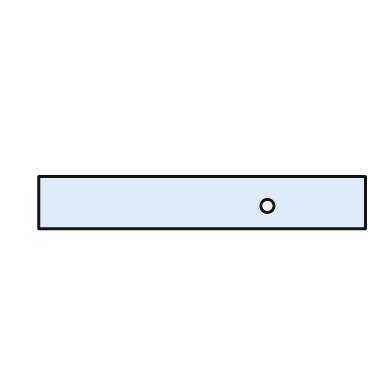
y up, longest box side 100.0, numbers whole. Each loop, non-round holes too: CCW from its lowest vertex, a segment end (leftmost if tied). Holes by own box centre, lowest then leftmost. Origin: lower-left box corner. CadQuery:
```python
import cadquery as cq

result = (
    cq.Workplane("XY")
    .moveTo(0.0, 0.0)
    .lineTo(100.0, 0.0)
    .lineTo(100.0, 16.0)
    .lineTo(0.0, 16.0)
    .close()
    .moveTo(70.0, 7.0)
    .circle(2.0)
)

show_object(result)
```